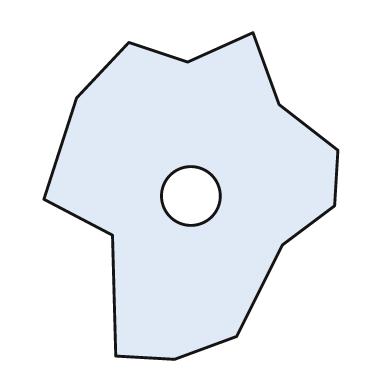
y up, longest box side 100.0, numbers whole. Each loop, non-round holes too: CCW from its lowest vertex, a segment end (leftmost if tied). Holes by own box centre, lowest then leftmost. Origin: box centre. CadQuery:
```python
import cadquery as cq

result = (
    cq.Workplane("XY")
    .moveTo(-5.0, -50.0)
    .lineTo(14.0, -43.0)
    .lineTo(28.0, -15.0)
    .lineTo(44.0, -3.0)
    .lineTo(45.0, 14.0)
    .lineTo(27.0, 28.0)
    .lineTo(19.0, 50.0)
    .lineTo(-1.0, 41.0)
    .lineTo(-19.0, 47.0)
    .lineTo(-35.0, 30.0)
    .lineTo(-45.0, -1.0)
    .lineTo(-24.0, -12.0)
    .lineTo(-23.0, -49.0)
    .close()
    .moveTo(0.0, 0.0)
    .circle(9.0)
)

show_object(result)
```